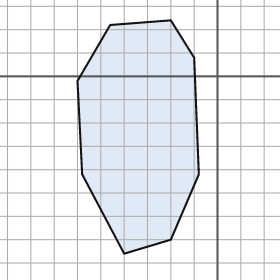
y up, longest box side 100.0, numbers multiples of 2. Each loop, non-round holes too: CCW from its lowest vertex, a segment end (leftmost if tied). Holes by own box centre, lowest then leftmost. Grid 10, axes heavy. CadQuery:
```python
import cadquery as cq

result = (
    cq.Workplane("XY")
    .moveTo(-40.0, -76.0)
    .lineTo(-20.0, -70.0)
    .lineTo(-8.0, -42.0)
    .lineTo(-10.0, 8.0)
    .lineTo(-20.0, 24.0)
    .lineTo(-46.0, 22.0)
    .lineTo(-60.0, -2.0)
    .lineTo(-58.0, -42.0)
    .close()
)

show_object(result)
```